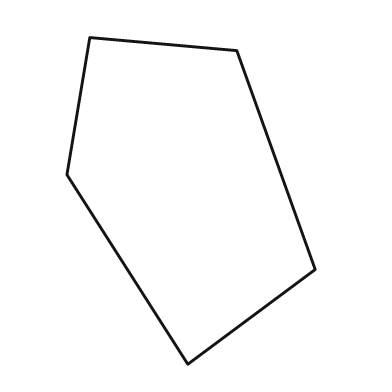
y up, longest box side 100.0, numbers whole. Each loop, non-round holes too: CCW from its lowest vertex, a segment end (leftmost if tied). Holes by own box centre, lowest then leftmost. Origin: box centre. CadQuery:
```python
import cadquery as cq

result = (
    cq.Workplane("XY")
    .moveTo(-1.0, -50.0)
    .lineTo(38.0, -21.0)
    .lineTo(14.0, 46.0)
    .lineTo(-31.0, 50.0)
    .lineTo(-38.0, 8.0)
    .close()
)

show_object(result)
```